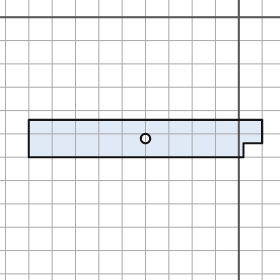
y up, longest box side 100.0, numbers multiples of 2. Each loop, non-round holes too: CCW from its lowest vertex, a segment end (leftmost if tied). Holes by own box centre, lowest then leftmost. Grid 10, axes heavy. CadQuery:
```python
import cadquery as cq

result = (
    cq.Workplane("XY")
    .moveTo(-90.0, -60.0)
    .lineTo(2.0, -60.0)
    .lineTo(2.0, -54.0)
    .lineTo(10.0, -54.0)
    .lineTo(10.0, -44.0)
    .lineTo(-90.0, -44.0)
    .close()
    .moveTo(-40.0, -52.0)
    .circle(2.0)
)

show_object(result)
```